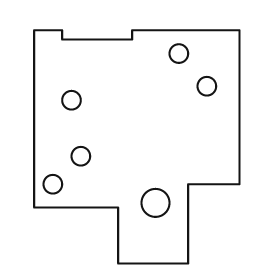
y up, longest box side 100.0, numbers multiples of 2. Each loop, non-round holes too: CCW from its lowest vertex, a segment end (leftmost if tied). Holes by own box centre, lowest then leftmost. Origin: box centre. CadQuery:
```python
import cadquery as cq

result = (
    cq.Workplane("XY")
    .moveTo(-8.0, -50.0)
    .lineTo(22.0, -50.0)
    .lineTo(22.0, -16.0)
    .lineTo(44.0, -16.0)
    .lineTo(44.0, 50.0)
    .lineTo(-2.0, 50.0)
    .lineTo(-2.0, 46.0)
    .lineTo(-32.0, 46.0)
    .lineTo(-32.0, 50.0)
    .lineTo(-44.0, 50.0)
    .lineTo(-44.0, -26.0)
    .lineTo(-8.0, -26.0)
    .close()
    .moveTo(8.0, -24.0)
    .circle(6.0)
    .moveTo(-36.0, -16.0)
    .circle(4.0)
    .moveTo(-24.0, -4.0)
    .circle(4.0)
    .moveTo(-28.0, 20.0)
    .circle(4.0)
    .moveTo(30.0, 26.0)
    .circle(4.0)
    .moveTo(18.0, 40.0)
    .circle(4.0)
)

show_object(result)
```